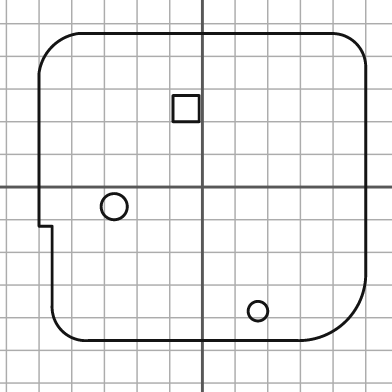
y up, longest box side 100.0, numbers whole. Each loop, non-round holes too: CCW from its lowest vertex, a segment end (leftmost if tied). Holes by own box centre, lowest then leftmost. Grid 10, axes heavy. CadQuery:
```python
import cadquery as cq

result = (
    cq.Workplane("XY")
    .moveTo(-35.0, -47.0)
    .lineTo(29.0, -47.0)
    .threePointArc((44.0, -41.0), (50.0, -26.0))
    .lineTo(50.0, 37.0)
    .threePointArc((47.0, 44.0), (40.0, 47.0))
    .lineTo(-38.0, 47.0)
    .threePointArc((-46.0, 43.0), (-50.0, 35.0))
    .lineTo(-50.0, -12.0)
    .lineTo(-46.0, -12.0)
    .lineTo(-46.0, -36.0)
    .threePointArc((-43.0, -44.0), (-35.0, -47.0))
    .close()
    .moveTo(17.0, -38.0)
    .circle(3.0)
    .moveTo(-27.0, -6.0)
    .circle(4.0)
    .moveTo(-9.0, 20.0)
    .lineTo(-1.0, 20.0)
    .lineTo(-1.0, 28.0)
    .lineTo(-9.0, 28.0)
    .close()
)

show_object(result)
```